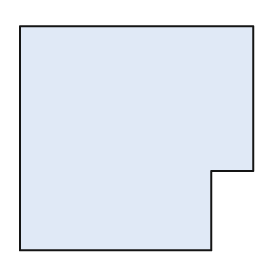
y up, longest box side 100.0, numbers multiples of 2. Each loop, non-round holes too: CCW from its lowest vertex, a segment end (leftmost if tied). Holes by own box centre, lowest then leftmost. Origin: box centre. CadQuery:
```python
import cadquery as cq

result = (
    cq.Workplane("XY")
    .moveTo(-50.0, -48.0)
    .lineTo(32.0, -48.0)
    .lineTo(32.0, -14.0)
    .lineTo(50.0, -14.0)
    .lineTo(50.0, 48.0)
    .lineTo(-50.0, 48.0)
    .close()
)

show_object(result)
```